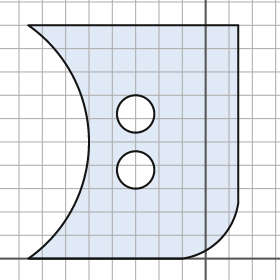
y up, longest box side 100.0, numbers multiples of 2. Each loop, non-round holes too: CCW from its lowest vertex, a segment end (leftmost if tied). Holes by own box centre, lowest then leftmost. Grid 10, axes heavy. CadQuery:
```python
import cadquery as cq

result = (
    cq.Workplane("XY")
    .moveTo(-76.0, 0.0)
    .lineTo(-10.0, 0.0)
    .threePointArc((6.0, 8.0), (14.0, 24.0))
    .lineTo(14.0, 100.0)
    .lineTo(-76.0, 100.0)
    .threePointArc((-50.0, 50.0), (-76.0, 0.0))
    .close()
    .moveTo(-30.0, 38.0)
    .circle(8.0)
    .moveTo(-30.0, 62.0)
    .circle(8.0)
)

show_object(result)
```